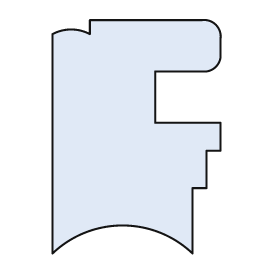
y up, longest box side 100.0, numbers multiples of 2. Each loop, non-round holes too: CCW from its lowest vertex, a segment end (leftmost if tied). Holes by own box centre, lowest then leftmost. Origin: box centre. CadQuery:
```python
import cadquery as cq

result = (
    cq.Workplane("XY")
    .moveTo(-36.0, -50.0)
    .threePointArc((-6.0, -38.0), (24.0, -50.0))
    .lineTo(24.0, -22.0)
    .lineTo(30.0, -22.0)
    .lineTo(30.0, -6.0)
    .lineTo(36.0, -6.0)
    .lineTo(36.0, 6.0)
    .lineTo(8.0, 6.0)
    .lineTo(8.0, 28.0)
    .lineTo(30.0, 28.0)
    .threePointArc((34.0, 30.0), (36.0, 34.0))
    .lineTo(36.0, 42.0)
    .threePointArc((34.0, 48.0), (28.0, 50.0))
    .lineTo(-20.0, 50.0)
    .lineTo(-20.0, 44.0)
    .threePointArc((-28.0, 46.0), (-36.0, 44.0))
    .close()
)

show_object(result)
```